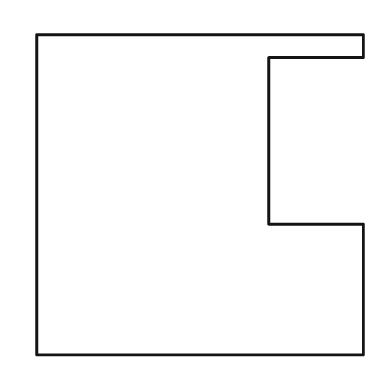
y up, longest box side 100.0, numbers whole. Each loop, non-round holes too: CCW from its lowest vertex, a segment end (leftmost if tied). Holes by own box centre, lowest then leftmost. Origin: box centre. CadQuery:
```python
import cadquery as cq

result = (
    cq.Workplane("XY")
    .moveTo(-50.0, -49.0)
    .lineTo(50.0, -49.0)
    .lineTo(50.0, -9.0)
    .lineTo(21.0, -9.0)
    .lineTo(21.0, 42.0)
    .lineTo(50.0, 42.0)
    .lineTo(50.0, 49.0)
    .lineTo(-50.0, 49.0)
    .close()
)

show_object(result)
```